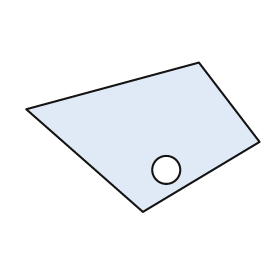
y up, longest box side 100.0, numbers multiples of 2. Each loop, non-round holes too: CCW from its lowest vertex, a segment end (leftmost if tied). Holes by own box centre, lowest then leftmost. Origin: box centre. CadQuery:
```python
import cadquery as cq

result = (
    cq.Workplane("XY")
    .moveTo(0.0, -32.0)
    .lineTo(50.0, -2.0)
    .lineTo(24.0, 32.0)
    .lineTo(-50.0, 12.0)
    .close()
    .moveTo(10.0, -14.0)
    .circle(6.0)
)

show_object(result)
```